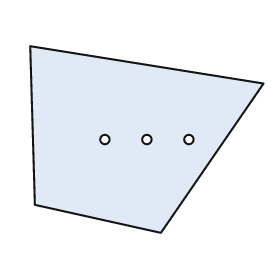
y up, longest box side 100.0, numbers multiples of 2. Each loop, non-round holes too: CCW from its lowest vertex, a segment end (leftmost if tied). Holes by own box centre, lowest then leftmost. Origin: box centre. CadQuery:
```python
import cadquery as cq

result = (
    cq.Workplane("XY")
    .moveTo(6.0, -40.0)
    .lineTo(50.0, 24.0)
    .lineTo(-50.0, 40.0)
    .lineTo(-48.0, -28.0)
    .close()
    .moveTo(-18.0, 0.0)
    .circle(2.0)
    .moveTo(0.0, 0.0)
    .circle(2.0)
    .moveTo(18.0, 0.0)
    .circle(2.0)
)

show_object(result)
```